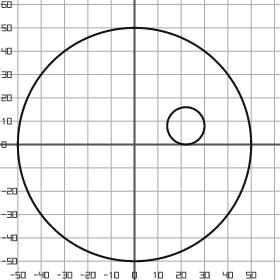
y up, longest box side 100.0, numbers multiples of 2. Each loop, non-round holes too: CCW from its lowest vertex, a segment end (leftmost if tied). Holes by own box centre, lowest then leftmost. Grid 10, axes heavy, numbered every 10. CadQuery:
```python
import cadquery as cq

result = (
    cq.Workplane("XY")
    .moveTo(0.0, 0.0)
    .circle(50.0)
    .moveTo(22.0, 8.0)
    .circle(8.0)
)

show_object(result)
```